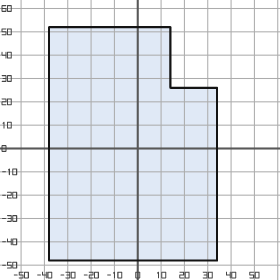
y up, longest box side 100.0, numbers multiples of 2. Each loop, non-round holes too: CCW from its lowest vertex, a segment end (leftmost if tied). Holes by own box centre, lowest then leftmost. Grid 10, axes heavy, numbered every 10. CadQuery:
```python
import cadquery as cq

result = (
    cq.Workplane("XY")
    .moveTo(-38.0, -48.0)
    .lineTo(34.0, -48.0)
    .lineTo(34.0, 26.0)
    .lineTo(14.0, 26.0)
    .lineTo(14.0, 52.0)
    .lineTo(-38.0, 52.0)
    .close()
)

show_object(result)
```